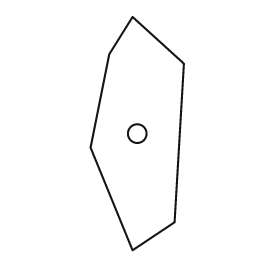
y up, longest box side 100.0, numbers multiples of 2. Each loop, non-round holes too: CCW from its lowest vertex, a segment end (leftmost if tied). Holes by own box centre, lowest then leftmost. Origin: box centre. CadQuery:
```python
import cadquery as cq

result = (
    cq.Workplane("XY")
    .moveTo(-2.0, -50.0)
    .lineTo(16.0, -38.0)
    .lineTo(20.0, 30.0)
    .lineTo(-2.0, 50.0)
    .lineTo(-12.0, 34.0)
    .lineTo(-20.0, -6.0)
    .close()
    .moveTo(0.0, 0.0)
    .circle(4.0)
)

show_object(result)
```